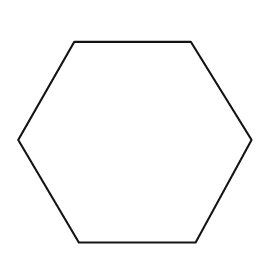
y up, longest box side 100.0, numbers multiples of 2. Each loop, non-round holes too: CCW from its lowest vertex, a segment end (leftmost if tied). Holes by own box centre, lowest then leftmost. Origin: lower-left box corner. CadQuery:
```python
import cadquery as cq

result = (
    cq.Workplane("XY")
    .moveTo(26.0, 0.0)
    .lineTo(76.0, 0.0)
    .lineTo(100.0, 44.0)
    .lineTo(74.0, 86.0)
    .lineTo(24.0, 86.0)
    .lineTo(0.0, 44.0)
    .close()
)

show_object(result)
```